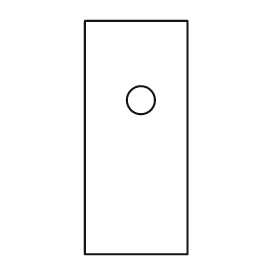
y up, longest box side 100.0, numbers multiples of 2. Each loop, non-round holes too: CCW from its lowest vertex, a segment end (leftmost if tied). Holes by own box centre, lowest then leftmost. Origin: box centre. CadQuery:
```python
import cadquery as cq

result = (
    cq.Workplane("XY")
    .moveTo(-22.0, -50.0)
    .lineTo(22.0, -50.0)
    .lineTo(22.0, 50.0)
    .lineTo(-22.0, 50.0)
    .close()
    .moveTo(2.0, 16.0)
    .circle(6.0)
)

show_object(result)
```